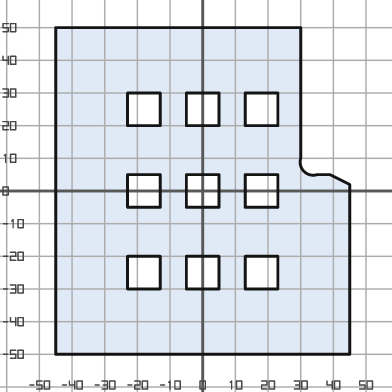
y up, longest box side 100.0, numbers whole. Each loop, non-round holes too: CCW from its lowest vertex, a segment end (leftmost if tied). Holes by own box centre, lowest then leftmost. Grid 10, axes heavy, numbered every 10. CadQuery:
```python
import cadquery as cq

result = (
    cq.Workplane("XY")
    .moveTo(-45.0, -50.0)
    .lineTo(45.0, -50.0)
    .lineTo(45.0, 2.0)
    .lineTo(39.0, 5.0)
    .lineTo(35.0, 5.0)
    .threePointArc((31.0, 6.0), (30.0, 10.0))
    .lineTo(30.0, 50.0)
    .lineTo(-45.0, 50.0)
    .close()
    .moveTo(-23.0, -30.0)
    .lineTo(-13.0, -30.0)
    .lineTo(-13.0, -20.0)
    .lineTo(-23.0, -20.0)
    .close()
    .moveTo(-5.0, -30.0)
    .lineTo(5.0, -30.0)
    .lineTo(5.0, -20.0)
    .lineTo(-5.0, -20.0)
    .close()
    .moveTo(13.0, -30.0)
    .lineTo(23.0, -30.0)
    .lineTo(23.0, -20.0)
    .lineTo(13.0, -20.0)
    .close()
    .moveTo(-23.0, -5.0)
    .lineTo(-13.0, -5.0)
    .lineTo(-13.0, 5.0)
    .lineTo(-23.0, 5.0)
    .close()
    .moveTo(-5.0, -5.0)
    .lineTo(5.0, -5.0)
    .lineTo(5.0, 5.0)
    .lineTo(-5.0, 5.0)
    .close()
    .moveTo(13.0, -5.0)
    .lineTo(23.0, -5.0)
    .lineTo(23.0, 5.0)
    .lineTo(13.0, 5.0)
    .close()
    .moveTo(-23.0, 20.0)
    .lineTo(-13.0, 20.0)
    .lineTo(-13.0, 30.0)
    .lineTo(-23.0, 30.0)
    .close()
    .moveTo(-5.0, 20.0)
    .lineTo(5.0, 20.0)
    .lineTo(5.0, 30.0)
    .lineTo(-5.0, 30.0)
    .close()
    .moveTo(13.0, 20.0)
    .lineTo(23.0, 20.0)
    .lineTo(23.0, 30.0)
    .lineTo(13.0, 30.0)
    .close()
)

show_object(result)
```